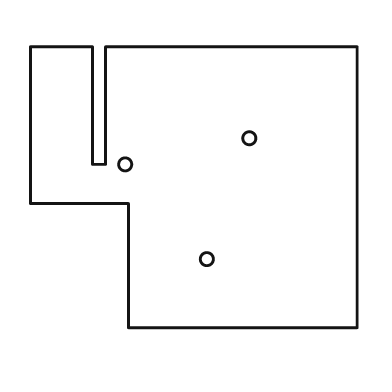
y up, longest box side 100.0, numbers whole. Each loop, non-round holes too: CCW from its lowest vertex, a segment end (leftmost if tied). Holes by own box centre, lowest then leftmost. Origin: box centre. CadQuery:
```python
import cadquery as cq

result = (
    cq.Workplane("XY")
    .moveTo(-20.0, -43.0)
    .lineTo(50.0, -43.0)
    .lineTo(50.0, 43.0)
    .lineTo(-27.0, 43.0)
    .lineTo(-27.0, 7.0)
    .lineTo(-31.0, 7.0)
    .lineTo(-31.0, 43.0)
    .lineTo(-50.0, 43.0)
    .lineTo(-50.0, -5.0)
    .lineTo(-20.0, -5.0)
    .close()
    .moveTo(4.0, -22.0)
    .circle(2.0)
    .moveTo(-21.0, 7.0)
    .circle(2.0)
    .moveTo(17.0, 15.0)
    .circle(2.0)
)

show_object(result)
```